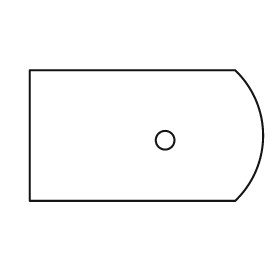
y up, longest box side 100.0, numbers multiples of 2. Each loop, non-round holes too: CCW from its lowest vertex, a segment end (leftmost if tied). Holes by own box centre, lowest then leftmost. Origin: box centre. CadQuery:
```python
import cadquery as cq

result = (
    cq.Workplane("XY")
    .moveTo(-50.0, -28.0)
    .lineTo(38.0, -28.0)
    .threePointArc((50.0, 0.0), (38.0, 28.0))
    .lineTo(-50.0, 28.0)
    .close()
    .moveTo(8.0, -2.0)
    .circle(4.0)
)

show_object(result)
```